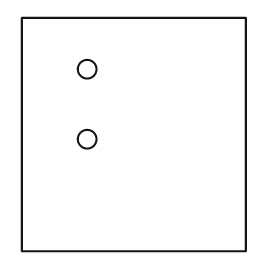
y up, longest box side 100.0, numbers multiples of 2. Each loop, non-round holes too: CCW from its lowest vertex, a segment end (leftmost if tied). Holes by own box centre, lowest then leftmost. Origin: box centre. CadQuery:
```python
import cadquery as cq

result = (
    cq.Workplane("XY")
    .moveTo(-48.0, -50.0)
    .lineTo(48.0, -50.0)
    .lineTo(48.0, 50.0)
    .lineTo(-48.0, 50.0)
    .close()
    .moveTo(-20.0, -2.0)
    .circle(4.0)
    .moveTo(-20.0, 28.0)
    .circle(4.0)
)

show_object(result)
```